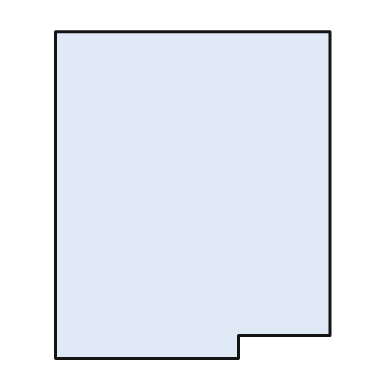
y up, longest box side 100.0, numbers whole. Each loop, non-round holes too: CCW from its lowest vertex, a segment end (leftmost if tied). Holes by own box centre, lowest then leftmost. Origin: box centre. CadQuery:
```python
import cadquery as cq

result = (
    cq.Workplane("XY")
    .moveTo(-42.0, -50.0)
    .lineTo(14.0, -50.0)
    .lineTo(14.0, -43.0)
    .lineTo(42.0, -43.0)
    .lineTo(42.0, 50.0)
    .lineTo(-42.0, 50.0)
    .close()
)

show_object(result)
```